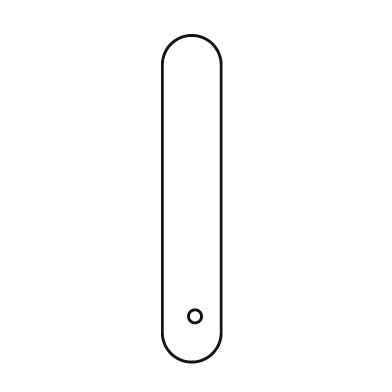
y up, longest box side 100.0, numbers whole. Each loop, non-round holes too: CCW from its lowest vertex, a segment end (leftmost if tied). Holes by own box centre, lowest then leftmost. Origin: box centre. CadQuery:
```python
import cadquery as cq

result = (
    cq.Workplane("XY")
    .moveTo(-9.0, -41.0)
    .threePointArc((0.0, -50.0), (9.0, -41.0))
    .lineTo(9.0, 41.0)
    .threePointArc((0.0, 50.0), (-9.0, 41.0))
    .close()
    .moveTo(1.0, -36.0)
    .circle(2.0)
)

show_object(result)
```